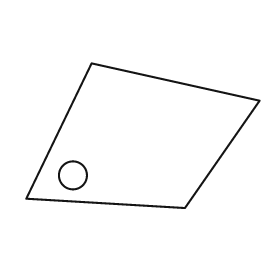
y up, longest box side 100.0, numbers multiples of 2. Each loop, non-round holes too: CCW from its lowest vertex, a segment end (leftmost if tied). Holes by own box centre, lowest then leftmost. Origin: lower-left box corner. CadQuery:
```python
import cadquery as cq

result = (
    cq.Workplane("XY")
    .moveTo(68.0, 0.0)
    .lineTo(100.0, 46.0)
    .lineTo(28.0, 62.0)
    .lineTo(0.0, 4.0)
    .close()
    .moveTo(20.0, 14.0)
    .circle(6.0)
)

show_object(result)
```